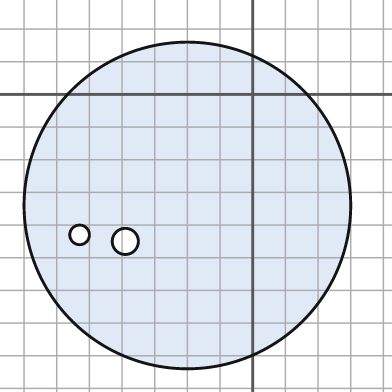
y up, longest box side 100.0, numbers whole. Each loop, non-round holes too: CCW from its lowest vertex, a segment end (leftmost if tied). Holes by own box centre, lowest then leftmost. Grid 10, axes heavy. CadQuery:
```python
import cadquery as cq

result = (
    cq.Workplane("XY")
    .moveTo(-20.0, -34.0)
    .circle(50.0)
    .moveTo(-39.0, -45.0)
    .circle(4.0)
    .moveTo(-53.0, -43.0)
    .circle(3.0)
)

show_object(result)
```